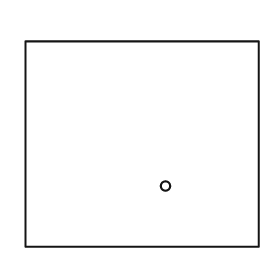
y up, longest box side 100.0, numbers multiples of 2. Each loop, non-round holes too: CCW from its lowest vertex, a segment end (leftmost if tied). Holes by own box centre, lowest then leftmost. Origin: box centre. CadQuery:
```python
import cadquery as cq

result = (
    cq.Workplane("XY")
    .moveTo(-50.0, -44.0)
    .lineTo(50.0, -44.0)
    .lineTo(50.0, 44.0)
    .lineTo(-50.0, 44.0)
    .close()
    .moveTo(10.0, -18.0)
    .circle(2.0)
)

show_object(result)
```